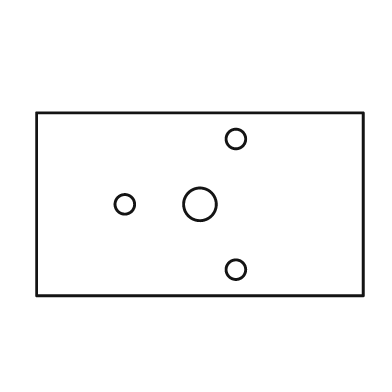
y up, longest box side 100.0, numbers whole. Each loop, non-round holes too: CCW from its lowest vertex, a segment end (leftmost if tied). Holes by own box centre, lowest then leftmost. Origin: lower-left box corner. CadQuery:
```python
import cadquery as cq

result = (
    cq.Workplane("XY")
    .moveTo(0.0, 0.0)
    .lineTo(100.0, 0.0)
    .lineTo(100.0, 56.0)
    .lineTo(0.0, 56.0)
    .close()
    .moveTo(61.0, 8.0)
    .circle(3.0)
    .moveTo(27.0, 28.0)
    .circle(3.0)
    .moveTo(50.0, 28.0)
    .circle(5.0)
    .moveTo(61.0, 48.0)
    .circle(3.0)
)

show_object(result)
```